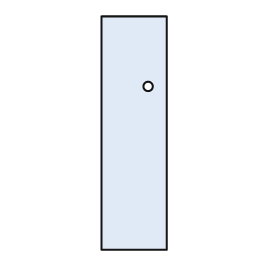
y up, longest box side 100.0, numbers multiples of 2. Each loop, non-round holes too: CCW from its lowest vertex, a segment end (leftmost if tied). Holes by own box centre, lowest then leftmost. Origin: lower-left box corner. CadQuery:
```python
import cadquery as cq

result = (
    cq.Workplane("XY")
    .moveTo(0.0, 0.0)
    .lineTo(28.0, 0.0)
    .lineTo(28.0, 100.0)
    .lineTo(0.0, 100.0)
    .close()
    .moveTo(20.0, 70.0)
    .circle(2.0)
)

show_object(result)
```